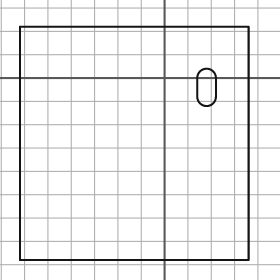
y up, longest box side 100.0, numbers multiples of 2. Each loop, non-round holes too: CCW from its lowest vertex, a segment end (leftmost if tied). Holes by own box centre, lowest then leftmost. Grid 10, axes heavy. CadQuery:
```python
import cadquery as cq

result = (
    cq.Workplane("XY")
    .moveTo(-62.0, -78.0)
    .lineTo(36.0, -78.0)
    .lineTo(36.0, 22.0)
    .lineTo(-62.0, 22.0)
    .close()
    .moveTo(14.0, -8.0)
    .threePointArc((18.0, -12.0), (22.0, -8.0))
    .lineTo(22.0, 0.0)
    .threePointArc((18.0, 4.0), (14.0, 0.0))
    .close()
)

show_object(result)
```